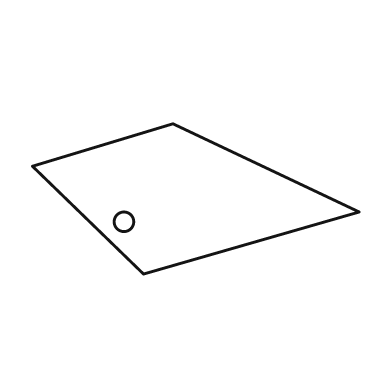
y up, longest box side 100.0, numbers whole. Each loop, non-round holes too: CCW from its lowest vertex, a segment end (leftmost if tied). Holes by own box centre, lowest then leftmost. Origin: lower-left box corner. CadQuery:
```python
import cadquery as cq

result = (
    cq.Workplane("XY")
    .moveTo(34.0, 0.0)
    .lineTo(100.0, 19.0)
    .lineTo(43.0, 46.0)
    .lineTo(0.0, 33.0)
    .close()
    .moveTo(28.0, 16.0)
    .circle(3.0)
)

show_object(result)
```